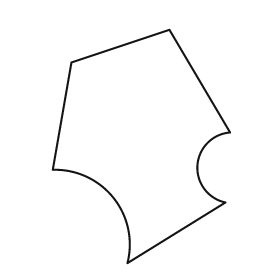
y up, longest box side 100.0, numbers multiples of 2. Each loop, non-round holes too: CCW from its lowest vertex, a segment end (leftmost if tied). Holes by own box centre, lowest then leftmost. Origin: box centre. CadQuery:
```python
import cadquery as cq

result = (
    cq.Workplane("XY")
    .moveTo(-6.0, -50.0)
    .lineTo(36.0, -24.0)
    .threePointArc((24.0, -8.0), (38.0, 6.0))
    .lineTo(12.0, 50.0)
    .lineTo(-30.0, 36.0)
    .lineTo(-38.0, -10.0)
    .threePointArc((-12.0, -22.0), (-6.0, -50.0))
    .close()
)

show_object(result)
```